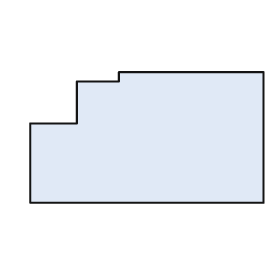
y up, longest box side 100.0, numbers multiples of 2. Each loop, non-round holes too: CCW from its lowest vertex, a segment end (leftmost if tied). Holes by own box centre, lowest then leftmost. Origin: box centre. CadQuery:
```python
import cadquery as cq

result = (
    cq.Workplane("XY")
    .moveTo(-50.0, -28.0)
    .lineTo(50.0, -28.0)
    .lineTo(50.0, 28.0)
    .lineTo(-12.0, 28.0)
    .lineTo(-12.0, 24.0)
    .lineTo(-30.0, 24.0)
    .lineTo(-30.0, 6.0)
    .lineTo(-50.0, 6.0)
    .close()
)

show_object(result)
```